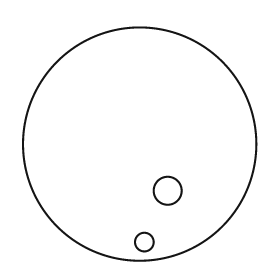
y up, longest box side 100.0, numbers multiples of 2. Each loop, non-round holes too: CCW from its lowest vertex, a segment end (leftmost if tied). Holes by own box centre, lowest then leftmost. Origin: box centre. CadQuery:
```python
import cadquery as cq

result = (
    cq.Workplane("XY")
    .moveTo(0.0, 0.0)
    .circle(50.0)
    .moveTo(2.0, -42.0)
    .circle(4.0)
    .moveTo(12.0, -20.0)
    .circle(6.0)
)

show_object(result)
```